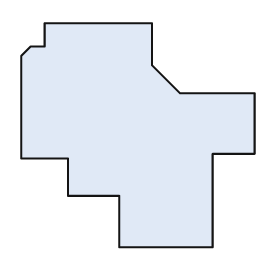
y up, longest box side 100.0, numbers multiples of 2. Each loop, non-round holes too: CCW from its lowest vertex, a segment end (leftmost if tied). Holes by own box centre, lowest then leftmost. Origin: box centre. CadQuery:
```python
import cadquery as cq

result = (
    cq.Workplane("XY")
    .moveTo(-8.0, -48.0)
    .lineTo(32.0, -48.0)
    .lineTo(32.0, -8.0)
    .lineTo(50.0, -8.0)
    .lineTo(50.0, 18.0)
    .lineTo(18.0, 18.0)
    .lineTo(6.0, 30.0)
    .lineTo(6.0, 48.0)
    .lineTo(-40.0, 48.0)
    .lineTo(-40.0, 38.0)
    .lineTo(-46.0, 38.0)
    .lineTo(-50.0, 34.0)
    .lineTo(-50.0, -10.0)
    .lineTo(-30.0, -10.0)
    .lineTo(-30.0, -26.0)
    .lineTo(-8.0, -26.0)
    .close()
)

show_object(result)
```